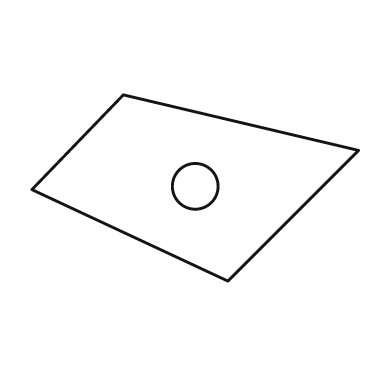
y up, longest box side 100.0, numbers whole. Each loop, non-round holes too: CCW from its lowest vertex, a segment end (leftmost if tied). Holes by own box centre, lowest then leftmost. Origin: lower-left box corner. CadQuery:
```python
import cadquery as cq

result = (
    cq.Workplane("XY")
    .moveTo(60.0, 0.0)
    .lineTo(100.0, 40.0)
    .lineTo(28.0, 57.0)
    .lineTo(0.0, 28.0)
    .close()
    .moveTo(50.0, 29.0)
    .circle(7.0)
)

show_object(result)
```